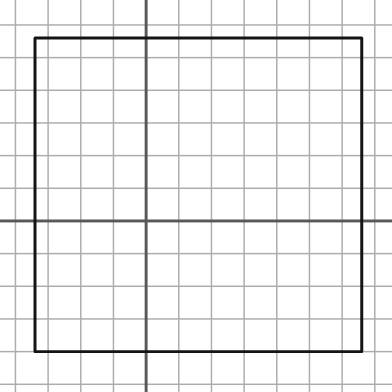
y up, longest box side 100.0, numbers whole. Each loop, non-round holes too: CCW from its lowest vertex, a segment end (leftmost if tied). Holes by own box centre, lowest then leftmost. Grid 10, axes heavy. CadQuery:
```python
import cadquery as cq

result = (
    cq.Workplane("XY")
    .moveTo(-34.0, -40.0)
    .lineTo(66.0, -40.0)
    .lineTo(66.0, 56.0)
    .lineTo(-34.0, 56.0)
    .close()
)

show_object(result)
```